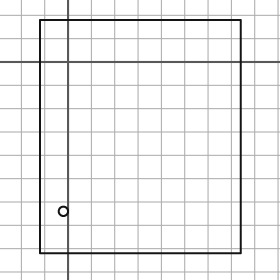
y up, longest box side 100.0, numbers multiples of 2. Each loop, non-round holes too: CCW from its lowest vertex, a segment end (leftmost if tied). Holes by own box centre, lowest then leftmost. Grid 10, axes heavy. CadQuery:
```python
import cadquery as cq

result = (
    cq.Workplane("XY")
    .moveTo(-12.0, -82.0)
    .lineTo(74.0, -82.0)
    .lineTo(74.0, 18.0)
    .lineTo(-12.0, 18.0)
    .close()
    .moveTo(-2.0, -64.0)
    .circle(2.0)
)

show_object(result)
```